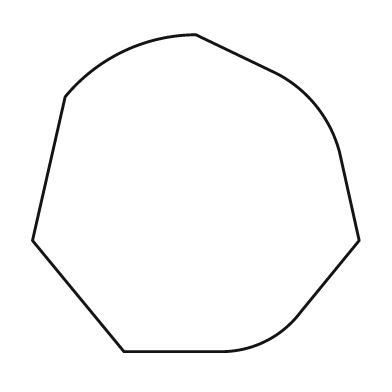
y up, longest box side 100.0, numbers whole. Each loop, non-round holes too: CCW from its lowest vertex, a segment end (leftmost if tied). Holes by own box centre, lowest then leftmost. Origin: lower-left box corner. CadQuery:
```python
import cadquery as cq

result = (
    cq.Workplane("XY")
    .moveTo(28.0, 0.0)
    .lineTo(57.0, 0.0)
    .threePointArc((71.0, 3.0), (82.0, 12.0))
    .lineTo(100.0, 34.0)
    .lineTo(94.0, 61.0)
    .threePointArc((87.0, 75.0), (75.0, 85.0))
    .lineTo(50.0, 97.0)
    .threePointArc((28.0, 92.0), (10.0, 78.0))
    .lineTo(0.0, 34.0)
    .close()
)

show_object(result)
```